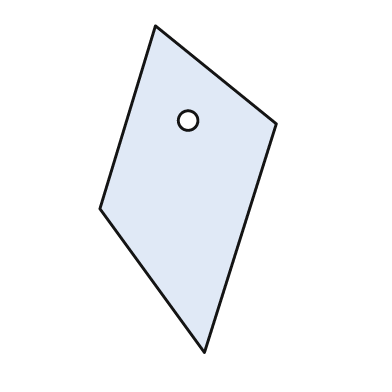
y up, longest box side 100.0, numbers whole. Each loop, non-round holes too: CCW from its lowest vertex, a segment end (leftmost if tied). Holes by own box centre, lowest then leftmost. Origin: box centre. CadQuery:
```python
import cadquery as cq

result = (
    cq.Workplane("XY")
    .moveTo(5.0, -50.0)
    .lineTo(27.0, 20.0)
    .lineTo(-10.0, 50.0)
    .lineTo(-27.0, -6.0)
    .close()
    .moveTo(0.0, 21.0)
    .circle(3.0)
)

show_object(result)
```